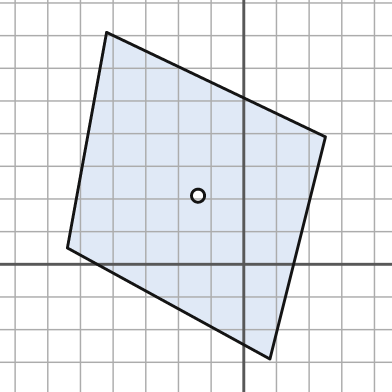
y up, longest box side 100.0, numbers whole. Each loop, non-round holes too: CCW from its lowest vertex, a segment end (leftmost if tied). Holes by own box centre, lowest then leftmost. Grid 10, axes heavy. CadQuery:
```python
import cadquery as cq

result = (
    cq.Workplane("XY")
    .moveTo(8.0, -29.0)
    .lineTo(25.0, 39.0)
    .lineTo(-42.0, 71.0)
    .lineTo(-54.0, 5.0)
    .close()
    .moveTo(-14.0, 21.0)
    .circle(2.0)
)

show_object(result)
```